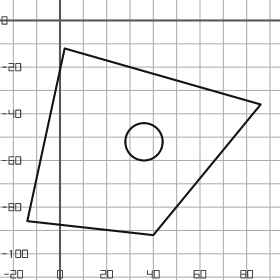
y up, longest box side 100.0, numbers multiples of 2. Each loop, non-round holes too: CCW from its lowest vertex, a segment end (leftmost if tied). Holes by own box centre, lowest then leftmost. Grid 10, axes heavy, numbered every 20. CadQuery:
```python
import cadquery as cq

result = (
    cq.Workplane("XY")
    .moveTo(40.0, -92.0)
    .lineTo(86.0, -36.0)
    .lineTo(2.0, -12.0)
    .lineTo(-14.0, -86.0)
    .close()
    .moveTo(36.0, -52.0)
    .circle(8.0)
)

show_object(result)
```